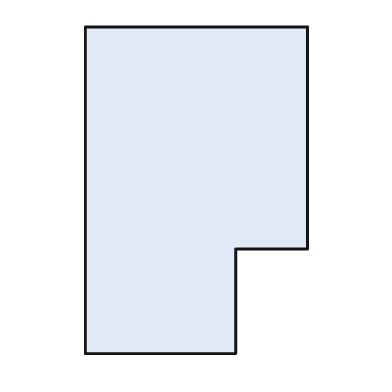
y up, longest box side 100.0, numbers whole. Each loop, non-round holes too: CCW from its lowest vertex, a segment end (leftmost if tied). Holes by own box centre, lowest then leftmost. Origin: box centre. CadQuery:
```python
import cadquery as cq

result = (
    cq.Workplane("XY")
    .moveTo(-34.0, -50.0)
    .lineTo(12.0, -50.0)
    .lineTo(12.0, -18.0)
    .lineTo(34.0, -18.0)
    .lineTo(34.0, 50.0)
    .lineTo(-34.0, 50.0)
    .close()
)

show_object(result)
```